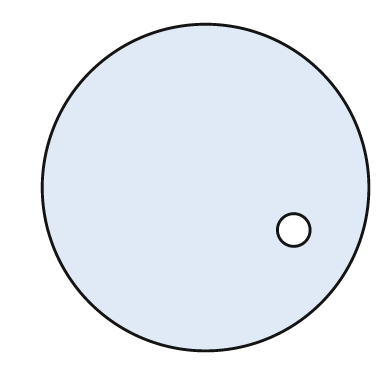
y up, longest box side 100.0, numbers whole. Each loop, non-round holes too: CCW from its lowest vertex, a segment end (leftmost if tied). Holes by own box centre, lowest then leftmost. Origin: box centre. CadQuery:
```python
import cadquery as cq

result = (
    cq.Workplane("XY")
    .moveTo(0.0, 0.0)
    .circle(50.0)
    .moveTo(27.0, -13.0)
    .circle(5.0)
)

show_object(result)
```